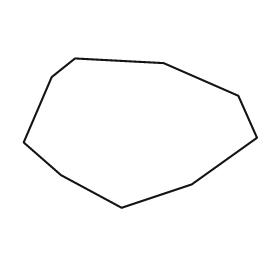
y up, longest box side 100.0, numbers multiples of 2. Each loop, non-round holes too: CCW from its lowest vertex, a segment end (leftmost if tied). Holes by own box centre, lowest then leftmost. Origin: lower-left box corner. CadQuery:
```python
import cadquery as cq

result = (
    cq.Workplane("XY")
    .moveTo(42.0, 0.0)
    .lineTo(72.0, 10.0)
    .lineTo(100.0, 30.0)
    .lineTo(92.0, 48.0)
    .lineTo(60.0, 62.0)
    .lineTo(22.0, 64.0)
    .lineTo(12.0, 56.0)
    .lineTo(0.0, 28.0)
    .lineTo(16.0, 14.0)
    .close()
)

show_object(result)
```